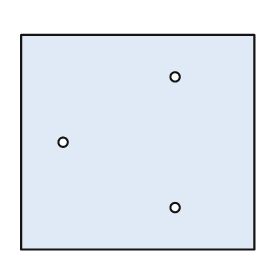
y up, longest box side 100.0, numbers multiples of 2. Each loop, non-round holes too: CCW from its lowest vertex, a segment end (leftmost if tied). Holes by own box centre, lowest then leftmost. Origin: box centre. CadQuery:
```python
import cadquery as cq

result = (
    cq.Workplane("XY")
    .moveTo(-50.0, -46.0)
    .lineTo(50.0, -46.0)
    .lineTo(50.0, 46.0)
    .lineTo(-50.0, 46.0)
    .close()
    .moveTo(16.0, -28.0)
    .circle(2.0)
    .moveTo(-32.0, 0.0)
    .circle(2.0)
    .moveTo(16.0, 28.0)
    .circle(2.0)
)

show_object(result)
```